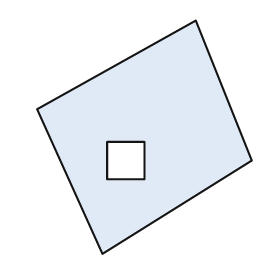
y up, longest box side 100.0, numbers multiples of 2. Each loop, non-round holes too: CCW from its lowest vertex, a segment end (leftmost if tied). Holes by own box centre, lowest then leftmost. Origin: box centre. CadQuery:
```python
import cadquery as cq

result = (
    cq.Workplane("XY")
    .moveTo(-18.0, -50.0)
    .lineTo(46.0, -10.0)
    .lineTo(22.0, 50.0)
    .lineTo(-46.0, 12.0)
    .close()
    .moveTo(-16.0, -18.0)
    .lineTo(0.0, -18.0)
    .lineTo(0.0, -2.0)
    .lineTo(-16.0, -2.0)
    .close()
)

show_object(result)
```